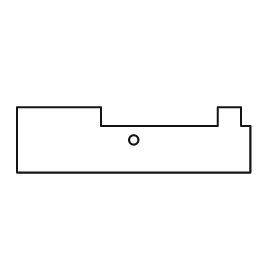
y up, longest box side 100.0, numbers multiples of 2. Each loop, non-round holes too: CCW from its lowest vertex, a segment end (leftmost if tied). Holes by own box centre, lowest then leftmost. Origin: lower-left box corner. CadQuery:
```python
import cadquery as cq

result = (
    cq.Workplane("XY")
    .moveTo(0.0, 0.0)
    .lineTo(100.0, 0.0)
    .lineTo(100.0, 20.0)
    .lineTo(96.0, 20.0)
    .lineTo(96.0, 28.0)
    .lineTo(86.0, 28.0)
    .lineTo(86.0, 20.0)
    .lineTo(36.0, 20.0)
    .lineTo(36.0, 28.0)
    .lineTo(0.0, 28.0)
    .close()
    .moveTo(50.0, 14.0)
    .circle(2.0)
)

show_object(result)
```